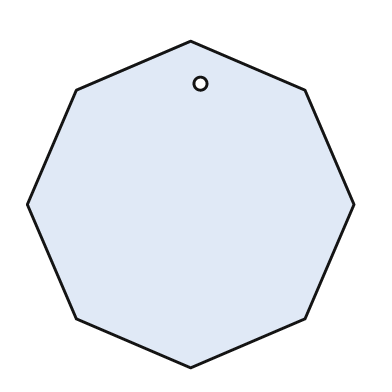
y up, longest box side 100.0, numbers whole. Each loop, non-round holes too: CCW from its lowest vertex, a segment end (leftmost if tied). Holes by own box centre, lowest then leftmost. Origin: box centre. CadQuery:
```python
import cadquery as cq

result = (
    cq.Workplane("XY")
    .moveTo(0.0, -50.0)
    .lineTo(35.0, -35.0)
    .lineTo(50.0, 0.0)
    .lineTo(35.0, 35.0)
    .lineTo(0.0, 50.0)
    .lineTo(-35.0, 35.0)
    .lineTo(-50.0, 0.0)
    .lineTo(-35.0, -35.0)
    .close()
    .moveTo(3.0, 37.0)
    .circle(2.0)
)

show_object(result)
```